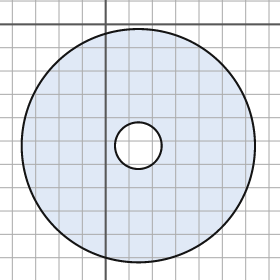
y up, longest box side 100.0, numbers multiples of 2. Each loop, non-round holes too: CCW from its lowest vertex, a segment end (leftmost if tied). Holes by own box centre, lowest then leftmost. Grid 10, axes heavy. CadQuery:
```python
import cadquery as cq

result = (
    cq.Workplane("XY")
    .moveTo(14.0, -52.0)
    .circle(50.0)
    .moveTo(14.0, -52.0)
    .circle(10.0)
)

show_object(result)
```